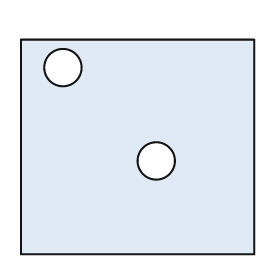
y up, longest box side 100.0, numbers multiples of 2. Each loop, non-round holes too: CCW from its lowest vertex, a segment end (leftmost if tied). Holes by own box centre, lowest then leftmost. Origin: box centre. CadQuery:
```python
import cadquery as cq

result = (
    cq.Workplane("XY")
    .moveTo(-50.0, -46.0)
    .lineTo(50.0, -46.0)
    .lineTo(50.0, 46.0)
    .lineTo(-50.0, 46.0)
    .close()
    .moveTo(8.0, -6.0)
    .circle(8.0)
    .moveTo(-32.0, 34.0)
    .circle(8.0)
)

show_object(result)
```